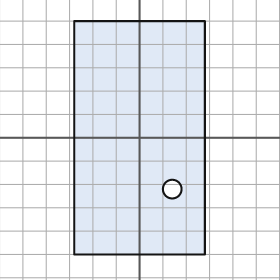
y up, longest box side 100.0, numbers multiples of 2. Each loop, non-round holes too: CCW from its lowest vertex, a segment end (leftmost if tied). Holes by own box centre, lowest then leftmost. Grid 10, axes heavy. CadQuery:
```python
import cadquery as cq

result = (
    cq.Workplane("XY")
    .moveTo(-28.0, -50.0)
    .lineTo(28.0, -50.0)
    .lineTo(28.0, 50.0)
    .lineTo(-28.0, 50.0)
    .close()
    .moveTo(14.0, -22.0)
    .circle(4.0)
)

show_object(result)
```